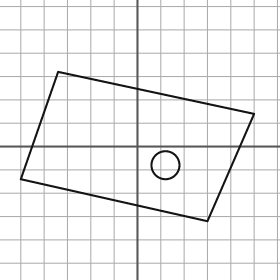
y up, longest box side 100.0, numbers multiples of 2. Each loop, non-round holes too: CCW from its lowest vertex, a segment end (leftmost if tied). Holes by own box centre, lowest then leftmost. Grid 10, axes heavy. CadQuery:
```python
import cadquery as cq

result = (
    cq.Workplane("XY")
    .moveTo(30.0, -32.0)
    .lineTo(50.0, 14.0)
    .lineTo(-34.0, 32.0)
    .lineTo(-50.0, -14.0)
    .close()
    .moveTo(12.0, -8.0)
    .circle(6.0)
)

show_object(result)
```